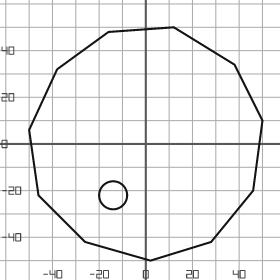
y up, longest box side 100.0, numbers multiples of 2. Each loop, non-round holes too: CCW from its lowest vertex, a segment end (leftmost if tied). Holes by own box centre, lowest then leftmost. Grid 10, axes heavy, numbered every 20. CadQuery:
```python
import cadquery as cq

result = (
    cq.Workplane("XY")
    .moveTo(2.0, -50.0)
    .lineTo(28.0, -42.0)
    .lineTo(46.0, -20.0)
    .lineTo(50.0, 10.0)
    .lineTo(38.0, 34.0)
    .lineTo(12.0, 50.0)
    .lineTo(-16.0, 48.0)
    .lineTo(-38.0, 32.0)
    .lineTo(-50.0, 6.0)
    .lineTo(-46.0, -22.0)
    .lineTo(-26.0, -42.0)
    .close()
    .moveTo(-14.0, -22.0)
    .circle(6.0)
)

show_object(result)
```